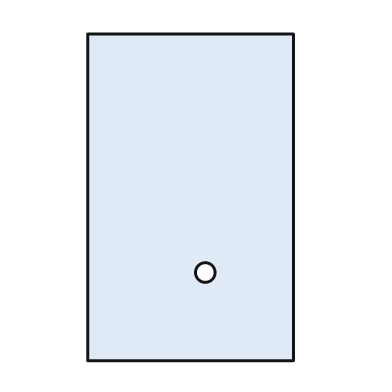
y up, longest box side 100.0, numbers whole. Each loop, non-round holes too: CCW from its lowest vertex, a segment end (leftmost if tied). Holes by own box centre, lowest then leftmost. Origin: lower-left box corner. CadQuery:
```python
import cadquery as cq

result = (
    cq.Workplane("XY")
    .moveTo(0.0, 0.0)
    .lineTo(63.0, 0.0)
    .lineTo(63.0, 100.0)
    .lineTo(0.0, 100.0)
    .close()
    .moveTo(36.0, 27.0)
    .circle(3.0)
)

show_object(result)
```